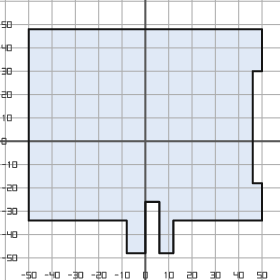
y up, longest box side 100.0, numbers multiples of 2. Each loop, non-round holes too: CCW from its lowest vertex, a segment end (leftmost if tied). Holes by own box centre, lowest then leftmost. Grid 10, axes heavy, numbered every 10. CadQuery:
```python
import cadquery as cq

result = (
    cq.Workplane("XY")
    .moveTo(-8.0, -48.0)
    .lineTo(0.0, -48.0)
    .lineTo(0.0, -26.0)
    .lineTo(6.0, -26.0)
    .lineTo(6.0, -48.0)
    .lineTo(12.0, -48.0)
    .lineTo(12.0, -34.0)
    .lineTo(50.0, -34.0)
    .lineTo(50.0, -18.0)
    .lineTo(46.0, -18.0)
    .lineTo(46.0, 30.0)
    .lineTo(50.0, 30.0)
    .lineTo(50.0, 48.0)
    .lineTo(-50.0, 48.0)
    .lineTo(-50.0, -34.0)
    .lineTo(-8.0, -34.0)
    .close()
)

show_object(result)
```